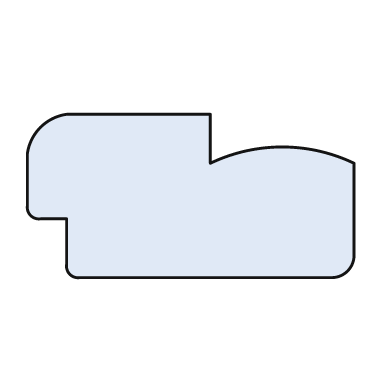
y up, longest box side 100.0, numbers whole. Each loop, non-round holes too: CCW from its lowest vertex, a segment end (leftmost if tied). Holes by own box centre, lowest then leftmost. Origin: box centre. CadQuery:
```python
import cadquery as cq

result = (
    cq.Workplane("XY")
    .moveTo(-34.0, -25.0)
    .lineTo(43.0, -25.0)
    .threePointArc((48.0, -23.0), (50.0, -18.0))
    .lineTo(50.0, 10.0)
    .threePointArc((28.0, 15.0), (6.0, 10.0))
    .lineTo(6.0, 25.0)
    .lineTo(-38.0, 25.0)
    .threePointArc((-46.0, 21.0), (-50.0, 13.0))
    .lineTo(-50.0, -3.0)
    .threePointArc((-49.0, -6.0), (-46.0, -7.0))
    .lineTo(-38.0, -7.0)
    .lineTo(-38.0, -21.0)
    .threePointArc((-37.0, -24.0), (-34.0, -25.0))
    .close()
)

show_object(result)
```